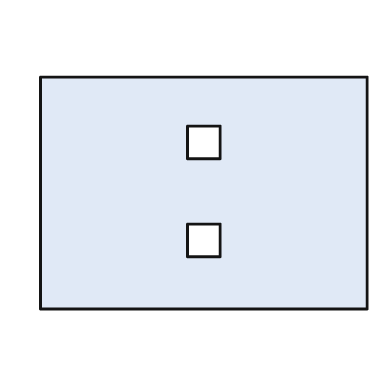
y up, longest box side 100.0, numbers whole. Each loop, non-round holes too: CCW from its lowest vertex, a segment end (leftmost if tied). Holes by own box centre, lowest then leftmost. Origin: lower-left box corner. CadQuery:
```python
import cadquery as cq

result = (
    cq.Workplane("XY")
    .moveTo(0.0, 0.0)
    .lineTo(100.0, 0.0)
    .lineTo(100.0, 71.0)
    .lineTo(0.0, 71.0)
    .close()
    .moveTo(45.0, 16.0)
    .lineTo(55.0, 16.0)
    .lineTo(55.0, 26.0)
    .lineTo(45.0, 26.0)
    .close()
    .moveTo(45.0, 46.0)
    .lineTo(55.0, 46.0)
    .lineTo(55.0, 56.0)
    .lineTo(45.0, 56.0)
    .close()
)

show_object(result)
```